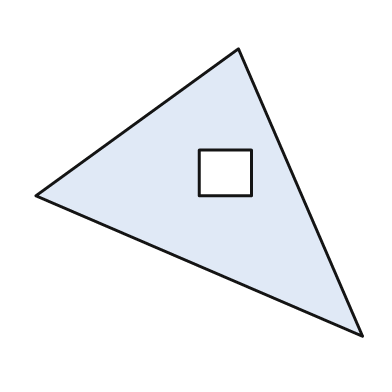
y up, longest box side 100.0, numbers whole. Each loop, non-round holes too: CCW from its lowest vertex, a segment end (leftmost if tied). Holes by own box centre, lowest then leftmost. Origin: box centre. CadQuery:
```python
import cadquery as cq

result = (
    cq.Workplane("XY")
    .moveTo(50.0, -44.0)
    .lineTo(12.0, 44.0)
    .lineTo(-50.0, -1.0)
    .close()
    .moveTo(0.0, -1.0)
    .lineTo(16.0, -1.0)
    .lineTo(16.0, 13.0)
    .lineTo(0.0, 13.0)
    .close()
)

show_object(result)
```